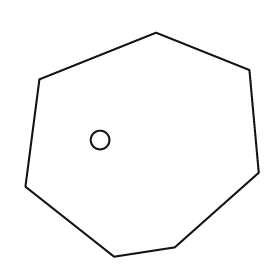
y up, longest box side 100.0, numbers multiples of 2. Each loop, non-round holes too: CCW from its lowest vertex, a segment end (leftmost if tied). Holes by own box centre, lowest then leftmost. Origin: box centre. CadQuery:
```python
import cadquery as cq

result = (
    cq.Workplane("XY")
    .moveTo(-12.0, -48.0)
    .lineTo(14.0, -44.0)
    .lineTo(50.0, -12.0)
    .lineTo(46.0, 32.0)
    .lineTo(6.0, 48.0)
    .lineTo(-44.0, 28.0)
    .lineTo(-50.0, -18.0)
    .close()
    .moveTo(-18.0, 2.0)
    .circle(4.0)
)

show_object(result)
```